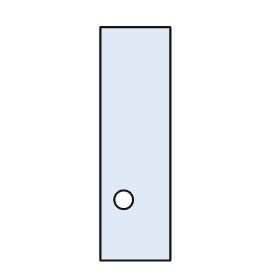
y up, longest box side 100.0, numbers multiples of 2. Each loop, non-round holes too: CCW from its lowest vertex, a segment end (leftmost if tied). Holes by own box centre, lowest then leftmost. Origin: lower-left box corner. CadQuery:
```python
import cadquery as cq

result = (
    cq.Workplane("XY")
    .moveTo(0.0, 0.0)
    .lineTo(30.0, 0.0)
    .lineTo(30.0, 100.0)
    .lineTo(0.0, 100.0)
    .close()
    .moveTo(10.0, 26.0)
    .circle(4.0)
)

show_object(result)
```